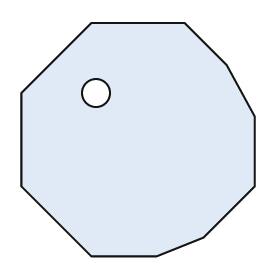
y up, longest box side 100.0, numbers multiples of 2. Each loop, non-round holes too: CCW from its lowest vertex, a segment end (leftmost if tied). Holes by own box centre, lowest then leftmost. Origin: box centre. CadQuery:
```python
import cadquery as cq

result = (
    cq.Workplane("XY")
    .moveTo(-20.0, -50.0)
    .lineTo(8.0, -50.0)
    .lineTo(28.0, -42.0)
    .lineTo(50.0, -20.0)
    .lineTo(50.0, 10.0)
    .lineTo(38.0, 32.0)
    .lineTo(20.0, 50.0)
    .lineTo(-20.0, 50.0)
    .lineTo(-50.0, 20.0)
    .lineTo(-50.0, -20.0)
    .close()
    .moveTo(-18.0, 20.0)
    .circle(6.0)
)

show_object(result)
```